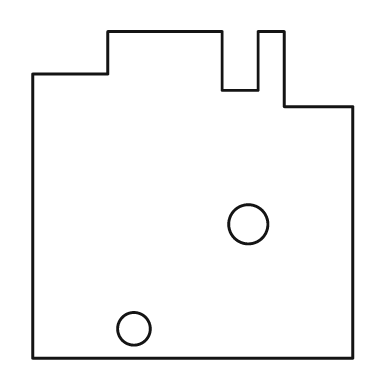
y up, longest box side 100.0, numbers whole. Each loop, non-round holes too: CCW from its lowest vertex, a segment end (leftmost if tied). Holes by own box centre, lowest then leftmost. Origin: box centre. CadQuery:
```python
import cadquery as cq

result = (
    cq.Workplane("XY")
    .moveTo(-49.0, -50.0)
    .lineTo(49.0, -50.0)
    .lineTo(49.0, 27.0)
    .lineTo(28.0, 27.0)
    .lineTo(28.0, 50.0)
    .lineTo(20.0, 50.0)
    .lineTo(20.0, 32.0)
    .lineTo(9.0, 32.0)
    .lineTo(9.0, 50.0)
    .lineTo(-26.0, 50.0)
    .lineTo(-26.0, 37.0)
    .lineTo(-49.0, 37.0)
    .close()
    .moveTo(-18.0, -41.0)
    .circle(5.0)
    .moveTo(17.0, -9.0)
    .circle(6.0)
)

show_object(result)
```